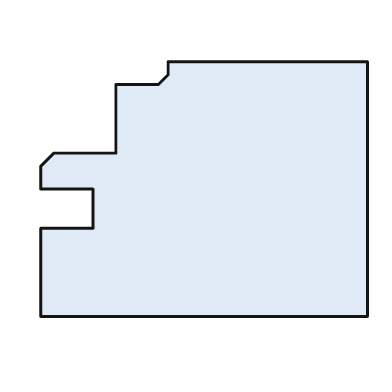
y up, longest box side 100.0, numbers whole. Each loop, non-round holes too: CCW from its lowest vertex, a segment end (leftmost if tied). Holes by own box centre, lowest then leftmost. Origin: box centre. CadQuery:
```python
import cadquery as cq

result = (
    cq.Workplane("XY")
    .moveTo(-50.0, -39.0)
    .lineTo(50.0, -39.0)
    .lineTo(50.0, 39.0)
    .lineTo(-11.0, 39.0)
    .lineTo(-11.0, 35.0)
    .lineTo(-14.0, 32.0)
    .lineTo(-27.0, 32.0)
    .lineTo(-27.0, 11.0)
    .lineTo(-46.0, 11.0)
    .lineTo(-50.0, 7.0)
    .lineTo(-50.0, 0.0)
    .lineTo(-34.0, 0.0)
    .lineTo(-34.0, -12.0)
    .lineTo(-50.0, -12.0)
    .close()
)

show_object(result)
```